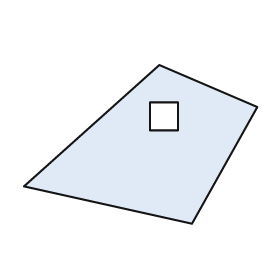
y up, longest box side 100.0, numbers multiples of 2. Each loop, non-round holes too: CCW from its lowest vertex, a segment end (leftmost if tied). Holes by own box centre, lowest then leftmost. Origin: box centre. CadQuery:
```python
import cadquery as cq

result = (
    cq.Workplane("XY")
    .moveTo(22.0, -34.0)
    .lineTo(50.0, 16.0)
    .lineTo(8.0, 34.0)
    .lineTo(-50.0, -18.0)
    .close()
    .moveTo(4.0, 6.0)
    .lineTo(16.0, 6.0)
    .lineTo(16.0, 18.0)
    .lineTo(4.0, 18.0)
    .close()
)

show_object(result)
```